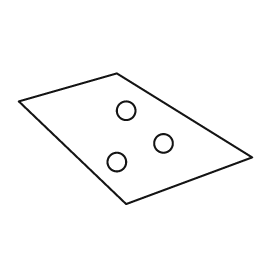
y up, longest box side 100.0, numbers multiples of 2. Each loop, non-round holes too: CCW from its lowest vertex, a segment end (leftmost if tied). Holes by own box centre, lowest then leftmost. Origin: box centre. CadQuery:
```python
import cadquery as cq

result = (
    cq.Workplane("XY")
    .moveTo(-4.0, -28.0)
    .lineTo(50.0, -8.0)
    .lineTo(-8.0, 28.0)
    .lineTo(-50.0, 16.0)
    .close()
    .moveTo(-8.0, -10.0)
    .circle(4.0)
    .moveTo(12.0, -2.0)
    .circle(4.0)
    .moveTo(-4.0, 12.0)
    .circle(4.0)
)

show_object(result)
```